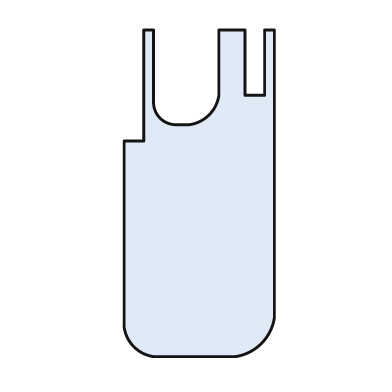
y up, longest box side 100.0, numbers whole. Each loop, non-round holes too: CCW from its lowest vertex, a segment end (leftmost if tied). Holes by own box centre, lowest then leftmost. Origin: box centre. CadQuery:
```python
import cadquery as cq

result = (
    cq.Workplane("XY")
    .moveTo(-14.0, -50.0)
    .lineTo(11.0, -50.0)
    .threePointArc((19.0, -46.0), (23.0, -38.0))
    .lineTo(23.0, 50.0)
    .lineTo(20.0, 50.0)
    .lineTo(20.0, 30.0)
    .lineTo(14.0, 30.0)
    .lineTo(14.0, 50.0)
    .lineTo(6.0, 50.0)
    .lineTo(6.0, 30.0)
    .threePointArc((3.0, 24.0), (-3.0, 21.0))
    .lineTo(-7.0, 21.0)
    .threePointArc((-12.0, 23.0), (-14.0, 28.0))
    .lineTo(-14.0, 50.0)
    .lineTo(-17.0, 50.0)
    .lineTo(-17.0, 16.0)
    .lineTo(-23.0, 16.0)
    .lineTo(-23.0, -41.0)
    .threePointArc((-20.0, -47.0), (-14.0, -50.0))
    .close()
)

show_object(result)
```